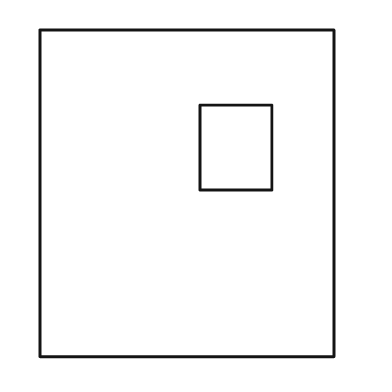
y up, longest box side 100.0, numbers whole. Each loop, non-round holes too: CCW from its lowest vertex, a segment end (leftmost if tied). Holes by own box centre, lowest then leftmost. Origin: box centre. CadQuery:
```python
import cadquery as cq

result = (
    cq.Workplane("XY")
    .moveTo(-45.0, -50.0)
    .lineTo(45.0, -50.0)
    .lineTo(45.0, 50.0)
    .lineTo(-45.0, 50.0)
    .close()
    .moveTo(4.0, 1.0)
    .lineTo(26.0, 1.0)
    .lineTo(26.0, 27.0)
    .lineTo(4.0, 27.0)
    .close()
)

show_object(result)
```